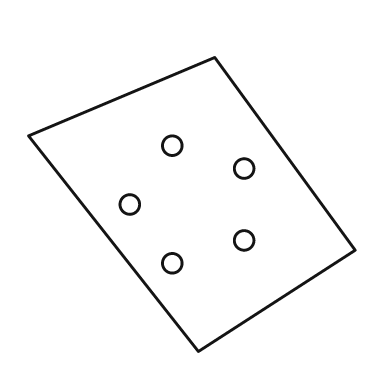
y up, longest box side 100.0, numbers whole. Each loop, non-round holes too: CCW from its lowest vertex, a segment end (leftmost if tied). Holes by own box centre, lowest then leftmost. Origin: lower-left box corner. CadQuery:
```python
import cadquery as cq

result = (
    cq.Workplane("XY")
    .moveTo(52.0, 0.0)
    .lineTo(100.0, 31.0)
    .lineTo(57.0, 90.0)
    .lineTo(0.0, 66.0)
    .close()
    .moveTo(44.0, 27.0)
    .circle(3.0)
    .moveTo(66.0, 34.0)
    .circle(3.0)
    .moveTo(31.0, 45.0)
    .circle(3.0)
    .moveTo(66.0, 56.0)
    .circle(3.0)
    .moveTo(44.0, 63.0)
    .circle(3.0)
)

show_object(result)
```